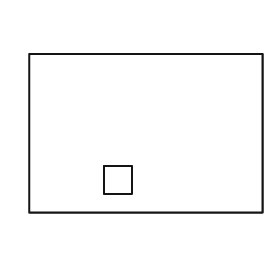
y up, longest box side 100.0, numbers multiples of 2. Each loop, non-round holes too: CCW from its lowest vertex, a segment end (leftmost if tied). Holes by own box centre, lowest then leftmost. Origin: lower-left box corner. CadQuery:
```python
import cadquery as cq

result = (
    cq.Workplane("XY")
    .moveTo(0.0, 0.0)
    .lineTo(100.0, 0.0)
    .lineTo(100.0, 68.0)
    .lineTo(0.0, 68.0)
    .close()
    .moveTo(32.0, 8.0)
    .lineTo(44.0, 8.0)
    .lineTo(44.0, 20.0)
    .lineTo(32.0, 20.0)
    .close()
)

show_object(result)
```